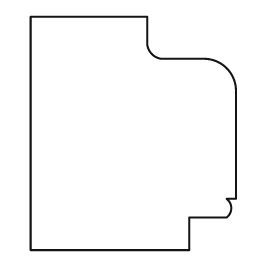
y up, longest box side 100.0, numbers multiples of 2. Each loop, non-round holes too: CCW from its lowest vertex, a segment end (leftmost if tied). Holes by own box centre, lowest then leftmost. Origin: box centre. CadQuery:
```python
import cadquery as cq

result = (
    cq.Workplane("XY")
    .moveTo(-44.0, -50.0)
    .lineTo(24.0, -50.0)
    .lineTo(24.0, -36.0)
    .lineTo(40.0, -36.0)
    .threePointArc((42.0, -32.0), (40.0, -28.0))
    .lineTo(44.0, -28.0)
    .lineTo(44.0, 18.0)
    .threePointArc((40.0, 28.0), (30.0, 32.0))
    .lineTo(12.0, 32.0)
    .threePointArc((8.0, 34.0), (6.0, 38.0))
    .lineTo(6.0, 50.0)
    .lineTo(-44.0, 50.0)
    .close()
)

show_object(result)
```